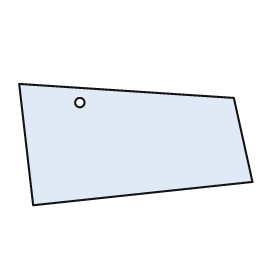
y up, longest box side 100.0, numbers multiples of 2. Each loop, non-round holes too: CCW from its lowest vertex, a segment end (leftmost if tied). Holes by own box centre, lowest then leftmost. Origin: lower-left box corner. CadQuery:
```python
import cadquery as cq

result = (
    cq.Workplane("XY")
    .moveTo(6.0, 0.0)
    .lineTo(100.0, 10.0)
    .lineTo(92.0, 46.0)
    .lineTo(0.0, 52.0)
    .close()
    .moveTo(26.0, 44.0)
    .circle(2.0)
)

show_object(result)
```